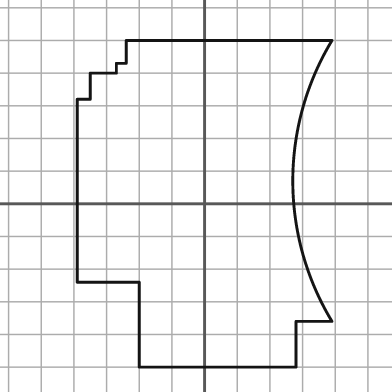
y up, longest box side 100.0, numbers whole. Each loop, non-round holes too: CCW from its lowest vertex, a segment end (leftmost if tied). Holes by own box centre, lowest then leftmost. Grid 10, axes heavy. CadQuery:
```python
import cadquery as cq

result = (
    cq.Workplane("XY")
    .moveTo(-20.0, -50.0)
    .lineTo(28.0, -50.0)
    .lineTo(28.0, -36.0)
    .lineTo(39.0, -36.0)
    .threePointArc((27.0, 7.0), (39.0, 50.0))
    .lineTo(-24.0, 50.0)
    .lineTo(-24.0, 43.0)
    .lineTo(-27.0, 43.0)
    .lineTo(-27.0, 40.0)
    .lineTo(-35.0, 40.0)
    .lineTo(-35.0, 32.0)
    .lineTo(-39.0, 32.0)
    .lineTo(-39.0, -24.0)
    .lineTo(-20.0, -24.0)
    .close()
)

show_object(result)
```